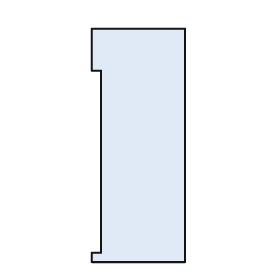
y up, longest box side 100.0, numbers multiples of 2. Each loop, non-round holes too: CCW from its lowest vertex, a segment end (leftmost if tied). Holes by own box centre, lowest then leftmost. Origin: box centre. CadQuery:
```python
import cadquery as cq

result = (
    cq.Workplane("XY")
    .moveTo(-20.0, -50.0)
    .lineTo(20.0, -50.0)
    .lineTo(20.0, 50.0)
    .lineTo(-20.0, 50.0)
    .lineTo(-20.0, 32.0)
    .lineTo(-16.0, 32.0)
    .lineTo(-16.0, -46.0)
    .lineTo(-20.0, -46.0)
    .close()
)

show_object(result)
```